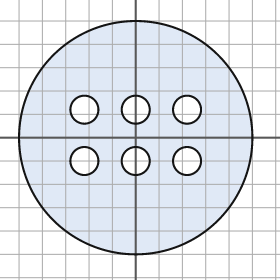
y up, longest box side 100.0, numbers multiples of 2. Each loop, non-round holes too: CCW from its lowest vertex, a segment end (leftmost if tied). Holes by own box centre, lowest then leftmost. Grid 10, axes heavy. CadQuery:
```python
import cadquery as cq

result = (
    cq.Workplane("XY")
    .moveTo(0.0, 0.0)
    .circle(50.0)
    .moveTo(-22.0, -10.0)
    .circle(6.0)
    .moveTo(0.0, -10.0)
    .circle(6.0)
    .moveTo(22.0, -10.0)
    .circle(6.0)
    .moveTo(-22.0, 12.0)
    .circle(6.0)
    .moveTo(0.0, 12.0)
    .circle(6.0)
    .moveTo(22.0, 12.0)
    .circle(6.0)
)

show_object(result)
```